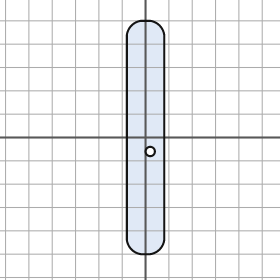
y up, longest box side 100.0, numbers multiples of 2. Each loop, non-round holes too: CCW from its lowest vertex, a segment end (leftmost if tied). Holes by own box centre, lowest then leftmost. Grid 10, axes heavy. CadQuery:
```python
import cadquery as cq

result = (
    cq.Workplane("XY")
    .moveTo(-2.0, -50.0)
    .lineTo(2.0, -50.0)
    .threePointArc((6.0, -48.0), (8.0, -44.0))
    .lineTo(8.0, 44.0)
    .threePointArc((6.0, 48.0), (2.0, 50.0))
    .lineTo(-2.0, 50.0)
    .threePointArc((-6.0, 48.0), (-8.0, 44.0))
    .lineTo(-8.0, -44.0)
    .threePointArc((-6.0, -48.0), (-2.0, -50.0))
    .close()
    .moveTo(2.0, -6.0)
    .circle(2.0)
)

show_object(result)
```